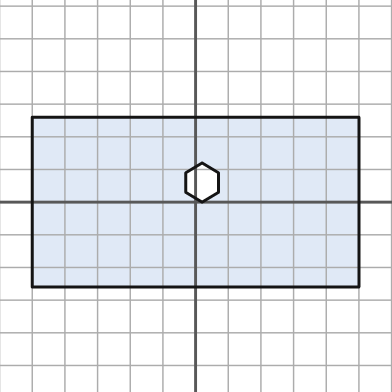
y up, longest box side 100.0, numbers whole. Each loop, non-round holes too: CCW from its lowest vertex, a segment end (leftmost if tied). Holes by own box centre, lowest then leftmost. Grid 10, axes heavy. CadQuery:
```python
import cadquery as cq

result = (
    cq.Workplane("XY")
    .moveTo(-50.0, -26.0)
    .lineTo(50.0, -26.0)
    .lineTo(50.0, 26.0)
    .lineTo(-50.0, 26.0)
    .close()
    .moveTo(2.0, 0.0)
    .lineTo(7.0, 3.0)
    .lineTo(7.0, 9.0)
    .lineTo(2.0, 12.0)
    .lineTo(-3.0, 9.0)
    .lineTo(-3.0, 3.0)
    .close()
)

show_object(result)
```